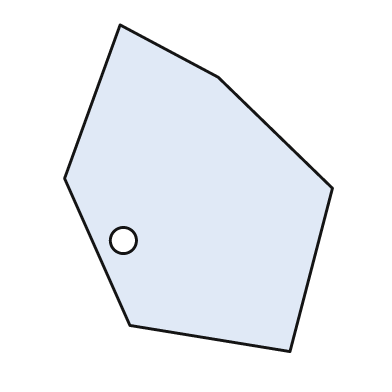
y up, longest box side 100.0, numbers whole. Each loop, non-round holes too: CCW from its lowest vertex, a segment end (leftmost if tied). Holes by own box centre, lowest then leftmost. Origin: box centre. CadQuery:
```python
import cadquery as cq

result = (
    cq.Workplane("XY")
    .moveTo(28.0, -50.0)
    .lineTo(41.0, 0.0)
    .lineTo(6.0, 34.0)
    .lineTo(-24.0, 50.0)
    .lineTo(-41.0, 3.0)
    .lineTo(-21.0, -42.0)
    .close()
    .moveTo(-23.0, -16.0)
    .circle(4.0)
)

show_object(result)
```